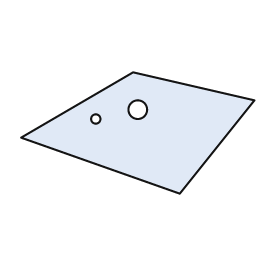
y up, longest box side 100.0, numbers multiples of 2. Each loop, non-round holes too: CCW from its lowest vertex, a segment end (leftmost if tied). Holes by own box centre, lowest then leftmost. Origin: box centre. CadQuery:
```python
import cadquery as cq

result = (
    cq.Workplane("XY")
    .moveTo(18.0, -26.0)
    .lineTo(50.0, 14.0)
    .lineTo(-2.0, 26.0)
    .lineTo(-50.0, -2.0)
    .close()
    .moveTo(-18.0, 6.0)
    .circle(2.0)
    .moveTo(0.0, 10.0)
    .circle(4.0)
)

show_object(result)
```